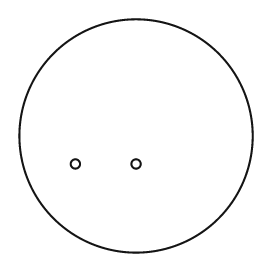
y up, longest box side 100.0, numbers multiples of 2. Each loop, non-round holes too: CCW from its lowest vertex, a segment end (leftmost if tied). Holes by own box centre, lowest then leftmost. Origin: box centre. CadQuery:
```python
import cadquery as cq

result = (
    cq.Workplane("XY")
    .moveTo(0.0, 0.0)
    .circle(50.0)
    .moveTo(-26.0, -12.0)
    .circle(2.0)
    .moveTo(0.0, -12.0)
    .circle(2.0)
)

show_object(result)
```